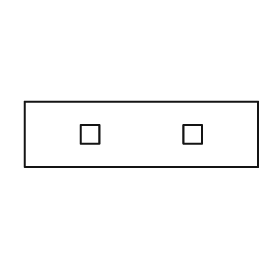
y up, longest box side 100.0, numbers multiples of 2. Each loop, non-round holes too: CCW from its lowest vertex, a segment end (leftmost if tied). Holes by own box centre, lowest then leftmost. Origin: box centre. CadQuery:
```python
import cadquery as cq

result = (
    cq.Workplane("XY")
    .moveTo(-50.0, -14.0)
    .lineTo(50.0, -14.0)
    .lineTo(50.0, 14.0)
    .lineTo(-50.0, 14.0)
    .close()
    .moveTo(-26.0, -4.0)
    .lineTo(-18.0, -4.0)
    .lineTo(-18.0, 4.0)
    .lineTo(-26.0, 4.0)
    .close()
    .moveTo(18.0, -4.0)
    .lineTo(26.0, -4.0)
    .lineTo(26.0, 4.0)
    .lineTo(18.0, 4.0)
    .close()
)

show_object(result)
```